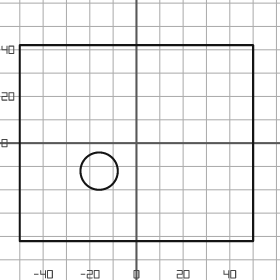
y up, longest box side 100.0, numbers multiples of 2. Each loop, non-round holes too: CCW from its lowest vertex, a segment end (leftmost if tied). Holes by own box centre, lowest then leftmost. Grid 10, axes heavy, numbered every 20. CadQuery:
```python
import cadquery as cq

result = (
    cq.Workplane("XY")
    .moveTo(-50.0, -42.0)
    .lineTo(50.0, -42.0)
    .lineTo(50.0, 42.0)
    .lineTo(-50.0, 42.0)
    .close()
    .moveTo(-16.0, -12.0)
    .circle(8.0)
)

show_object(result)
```